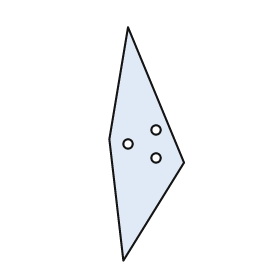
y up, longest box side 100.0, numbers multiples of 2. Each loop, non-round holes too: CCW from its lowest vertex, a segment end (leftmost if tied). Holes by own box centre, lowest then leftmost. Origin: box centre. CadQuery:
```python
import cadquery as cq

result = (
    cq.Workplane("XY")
    .moveTo(-10.0, -50.0)
    .lineTo(16.0, -8.0)
    .lineTo(-8.0, 50.0)
    .lineTo(-16.0, 2.0)
    .close()
    .moveTo(4.0, -6.0)
    .circle(2.0)
    .moveTo(-8.0, 0.0)
    .circle(2.0)
    .moveTo(4.0, 6.0)
    .circle(2.0)
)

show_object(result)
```